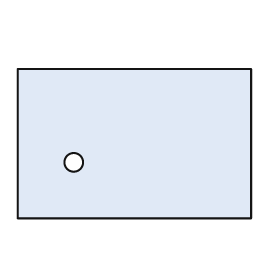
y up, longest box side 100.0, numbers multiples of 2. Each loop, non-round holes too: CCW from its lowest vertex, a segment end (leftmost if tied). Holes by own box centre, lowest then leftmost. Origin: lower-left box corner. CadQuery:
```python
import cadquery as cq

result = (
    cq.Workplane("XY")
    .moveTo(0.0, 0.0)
    .lineTo(100.0, 0.0)
    .lineTo(100.0, 64.0)
    .lineTo(0.0, 64.0)
    .close()
    .moveTo(24.0, 24.0)
    .circle(4.0)
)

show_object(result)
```